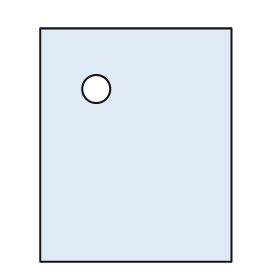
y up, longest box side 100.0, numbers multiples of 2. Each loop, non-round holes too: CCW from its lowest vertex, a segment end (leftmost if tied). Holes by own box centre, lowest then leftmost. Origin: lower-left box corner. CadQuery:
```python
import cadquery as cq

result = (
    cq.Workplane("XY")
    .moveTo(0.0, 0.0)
    .lineTo(82.0, 0.0)
    .lineTo(82.0, 100.0)
    .lineTo(0.0, 100.0)
    .close()
    .moveTo(24.0, 74.0)
    .circle(6.0)
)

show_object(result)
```